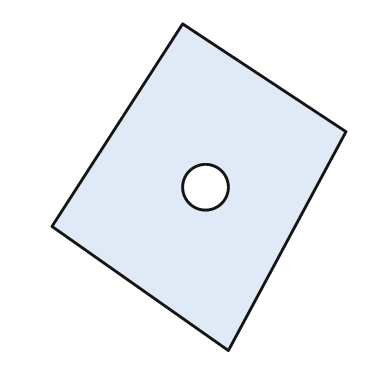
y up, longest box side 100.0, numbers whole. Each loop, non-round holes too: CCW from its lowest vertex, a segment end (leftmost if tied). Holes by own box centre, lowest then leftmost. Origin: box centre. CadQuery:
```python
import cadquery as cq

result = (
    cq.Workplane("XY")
    .moveTo(9.0, -50.0)
    .lineTo(45.0, 17.0)
    .lineTo(-5.0, 50.0)
    .lineTo(-45.0, -12.0)
    .close()
    .moveTo(2.0, 0.0)
    .circle(7.0)
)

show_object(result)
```